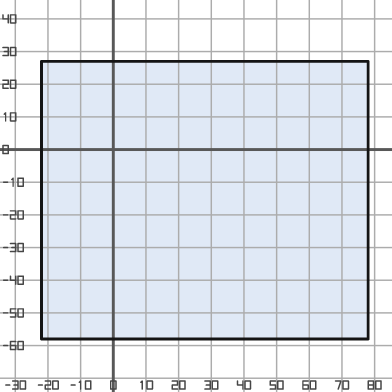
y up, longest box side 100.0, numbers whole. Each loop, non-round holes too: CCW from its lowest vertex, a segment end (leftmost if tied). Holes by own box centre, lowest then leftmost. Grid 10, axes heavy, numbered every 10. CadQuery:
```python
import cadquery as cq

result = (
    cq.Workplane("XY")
    .moveTo(-22.0, -58.0)
    .lineTo(78.0, -58.0)
    .lineTo(78.0, 27.0)
    .lineTo(-22.0, 27.0)
    .close()
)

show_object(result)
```